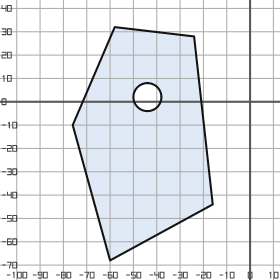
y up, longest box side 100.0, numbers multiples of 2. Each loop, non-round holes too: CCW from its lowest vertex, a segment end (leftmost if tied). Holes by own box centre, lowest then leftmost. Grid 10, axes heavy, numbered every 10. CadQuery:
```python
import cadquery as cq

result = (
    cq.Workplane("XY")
    .moveTo(-60.0, -68.0)
    .lineTo(-16.0, -44.0)
    .lineTo(-24.0, 28.0)
    .lineTo(-58.0, 32.0)
    .lineTo(-76.0, -10.0)
    .close()
    .moveTo(-44.0, 2.0)
    .circle(6.0)
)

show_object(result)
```